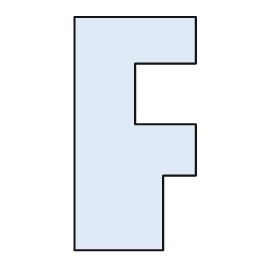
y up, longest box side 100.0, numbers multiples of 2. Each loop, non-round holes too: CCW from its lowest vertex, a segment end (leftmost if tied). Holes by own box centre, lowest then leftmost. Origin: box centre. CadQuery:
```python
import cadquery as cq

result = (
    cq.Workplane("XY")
    .moveTo(-26.0, -50.0)
    .lineTo(12.0, -50.0)
    .lineTo(12.0, -18.0)
    .lineTo(26.0, -18.0)
    .lineTo(26.0, 4.0)
    .lineTo(0.0, 4.0)
    .lineTo(0.0, 30.0)
    .lineTo(26.0, 30.0)
    .lineTo(26.0, 50.0)
    .lineTo(-26.0, 50.0)
    .close()
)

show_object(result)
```